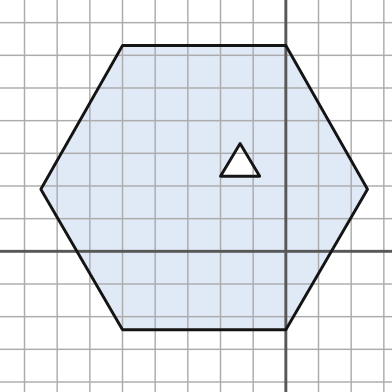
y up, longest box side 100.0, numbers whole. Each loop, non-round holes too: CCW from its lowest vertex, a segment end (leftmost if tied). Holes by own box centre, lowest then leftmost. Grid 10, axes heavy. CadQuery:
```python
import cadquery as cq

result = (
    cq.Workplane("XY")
    .moveTo(-50.0, -24.0)
    .lineTo(0.0, -24.0)
    .lineTo(25.0, 19.0)
    .lineTo(0.0, 63.0)
    .lineTo(-50.0, 63.0)
    .lineTo(-75.0, 19.0)
    .close()
    .moveTo(-20.0, 23.0)
    .lineTo(-8.0, 23.0)
    .lineTo(-14.0, 33.0)
    .close()
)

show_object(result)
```